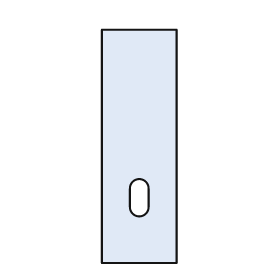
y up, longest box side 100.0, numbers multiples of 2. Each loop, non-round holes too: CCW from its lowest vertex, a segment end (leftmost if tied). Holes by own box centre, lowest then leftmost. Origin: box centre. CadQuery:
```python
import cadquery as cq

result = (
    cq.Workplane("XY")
    .moveTo(-16.0, -50.0)
    .lineTo(16.0, -50.0)
    .lineTo(16.0, 50.0)
    .lineTo(-16.0, 50.0)
    .close()
    .moveTo(-4.0, -26.0)
    .threePointArc((0.0, -30.0), (4.0, -26.0))
    .lineTo(4.0, -18.0)
    .threePointArc((0.0, -14.0), (-4.0, -18.0))
    .close()
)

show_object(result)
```